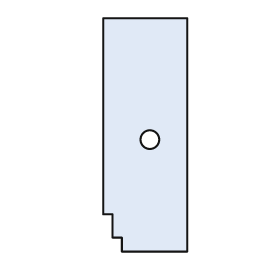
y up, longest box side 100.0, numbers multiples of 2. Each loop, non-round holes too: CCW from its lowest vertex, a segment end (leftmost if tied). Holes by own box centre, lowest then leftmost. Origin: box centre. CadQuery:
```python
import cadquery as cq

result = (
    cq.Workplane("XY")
    .moveTo(-10.0, -50.0)
    .lineTo(18.0, -50.0)
    .lineTo(18.0, 50.0)
    .lineTo(-18.0, 50.0)
    .lineTo(-18.0, -34.0)
    .lineTo(-14.0, -34.0)
    .lineTo(-14.0, -44.0)
    .lineTo(-10.0, -44.0)
    .close()
    .moveTo(2.0, -2.0)
    .circle(4.0)
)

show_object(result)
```